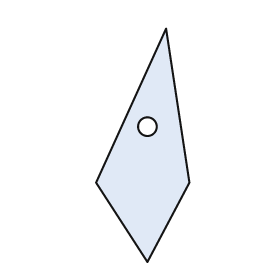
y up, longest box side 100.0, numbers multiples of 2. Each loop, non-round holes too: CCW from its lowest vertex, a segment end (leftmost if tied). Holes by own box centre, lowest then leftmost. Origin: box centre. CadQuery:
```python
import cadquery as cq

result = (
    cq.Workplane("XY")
    .moveTo(2.0, -50.0)
    .lineTo(20.0, -16.0)
    .lineTo(10.0, 50.0)
    .lineTo(-20.0, -16.0)
    .close()
    .moveTo(2.0, 8.0)
    .circle(4.0)
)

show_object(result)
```